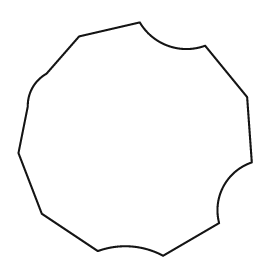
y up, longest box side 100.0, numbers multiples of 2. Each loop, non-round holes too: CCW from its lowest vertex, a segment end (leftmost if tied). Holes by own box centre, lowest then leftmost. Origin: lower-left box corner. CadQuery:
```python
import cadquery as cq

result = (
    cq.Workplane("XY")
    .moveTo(62.0, 0.0)
    .lineTo(86.0, 14.0)
    .threePointArc((88.0, 30.0), (100.0, 40.0))
    .lineTo(98.0, 68.0)
    .lineTo(80.0, 90.0)
    .threePointArc((64.0, 90.0), (52.0, 100.0))
    .lineTo(26.0, 94.0)
    .lineTo(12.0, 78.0)
    .threePointArc((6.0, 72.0), (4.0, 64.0))
    .lineTo(0.0, 44.0)
    .lineTo(10.0, 18.0)
    .lineTo(34.0, 2.0)
    .threePointArc((48.0, 4.0), (62.0, 0.0))
    .close()
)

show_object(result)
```